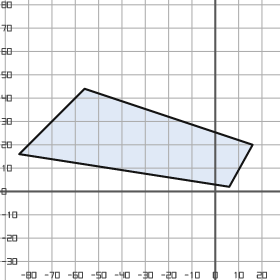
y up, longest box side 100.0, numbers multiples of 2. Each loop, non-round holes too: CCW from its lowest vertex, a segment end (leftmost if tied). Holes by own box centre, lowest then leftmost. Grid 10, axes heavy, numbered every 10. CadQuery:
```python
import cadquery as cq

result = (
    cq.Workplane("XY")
    .moveTo(6.0, 2.0)
    .lineTo(16.0, 20.0)
    .lineTo(-56.0, 44.0)
    .lineTo(-84.0, 16.0)
    .close()
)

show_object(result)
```